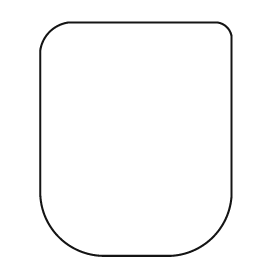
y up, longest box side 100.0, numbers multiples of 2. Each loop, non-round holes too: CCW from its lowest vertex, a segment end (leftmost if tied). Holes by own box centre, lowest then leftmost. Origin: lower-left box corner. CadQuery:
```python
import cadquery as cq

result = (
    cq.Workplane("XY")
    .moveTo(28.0, 0.0)
    .lineTo(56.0, 0.0)
    .threePointArc((74.0, 8.0), (82.0, 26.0))
    .lineTo(82.0, 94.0)
    .threePointArc((80.0, 98.0), (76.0, 100.0))
    .lineTo(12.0, 100.0)
    .threePointArc((4.0, 96.0), (0.0, 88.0))
    .lineTo(0.0, 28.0)
    .threePointArc((8.0, 8.0), (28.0, 0.0))
    .close()
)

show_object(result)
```